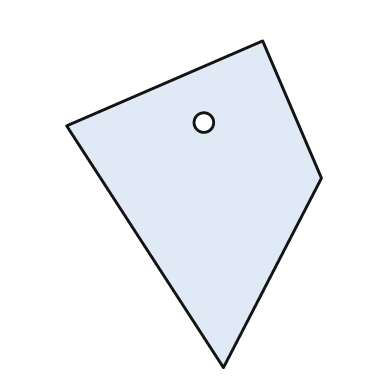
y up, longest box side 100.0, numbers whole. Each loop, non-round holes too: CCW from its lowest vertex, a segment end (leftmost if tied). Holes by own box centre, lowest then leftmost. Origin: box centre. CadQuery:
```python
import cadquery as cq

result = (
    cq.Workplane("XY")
    .moveTo(9.0, -50.0)
    .lineTo(39.0, 8.0)
    .lineTo(21.0, 50.0)
    .lineTo(-39.0, 24.0)
    .close()
    .moveTo(3.0, 25.0)
    .circle(3.0)
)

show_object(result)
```